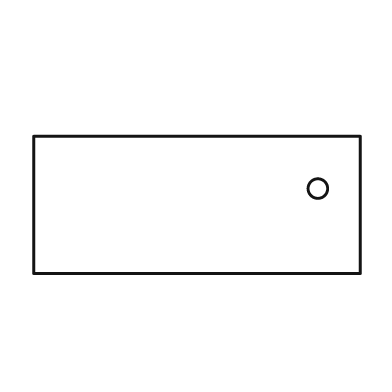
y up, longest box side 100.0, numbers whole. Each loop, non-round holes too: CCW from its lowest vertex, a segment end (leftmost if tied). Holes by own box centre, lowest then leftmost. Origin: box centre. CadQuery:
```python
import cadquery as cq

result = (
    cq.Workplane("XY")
    .moveTo(-50.0, -21.0)
    .lineTo(50.0, -21.0)
    .lineTo(50.0, 21.0)
    .lineTo(-50.0, 21.0)
    .close()
    .moveTo(37.0, 5.0)
    .circle(3.0)
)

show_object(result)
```